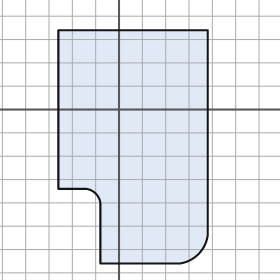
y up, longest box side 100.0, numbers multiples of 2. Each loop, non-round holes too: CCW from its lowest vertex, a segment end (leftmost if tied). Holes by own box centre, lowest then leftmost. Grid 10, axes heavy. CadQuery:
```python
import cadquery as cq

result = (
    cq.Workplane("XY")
    .moveTo(-8.0, -66.0)
    .lineTo(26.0, -66.0)
    .threePointArc((34.0, -62.0), (38.0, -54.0))
    .lineTo(38.0, 34.0)
    .lineTo(-26.0, 34.0)
    .lineTo(-26.0, -34.0)
    .lineTo(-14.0, -34.0)
    .threePointArc((-10.0, -36.0), (-8.0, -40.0))
    .close()
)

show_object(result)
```